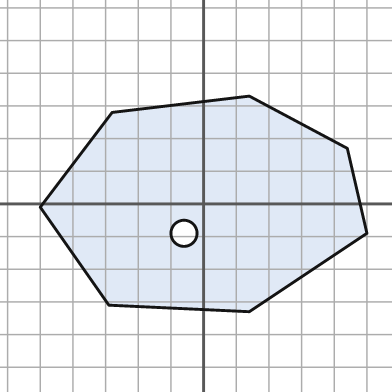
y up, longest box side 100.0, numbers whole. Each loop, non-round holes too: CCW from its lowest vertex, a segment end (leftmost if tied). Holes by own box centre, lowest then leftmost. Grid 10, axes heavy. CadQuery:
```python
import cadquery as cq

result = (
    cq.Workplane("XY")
    .moveTo(14.0, -33.0)
    .lineTo(50.0, -9.0)
    .lineTo(44.0, 17.0)
    .lineTo(14.0, 33.0)
    .lineTo(-28.0, 28.0)
    .lineTo(-50.0, -1.0)
    .lineTo(-29.0, -31.0)
    .close()
    .moveTo(-6.0, -9.0)
    .circle(4.0)
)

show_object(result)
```